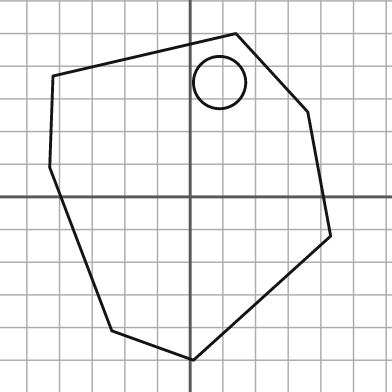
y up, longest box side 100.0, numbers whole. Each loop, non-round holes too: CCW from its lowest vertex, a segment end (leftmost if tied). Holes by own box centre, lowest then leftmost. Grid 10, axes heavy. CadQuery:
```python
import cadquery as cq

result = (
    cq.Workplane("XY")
    .moveTo(1.0, -50.0)
    .lineTo(43.0, -12.0)
    .lineTo(36.0, 26.0)
    .lineTo(14.0, 50.0)
    .lineTo(-42.0, 37.0)
    .lineTo(-43.0, 9.0)
    .lineTo(-24.0, -41.0)
    .close()
    .moveTo(9.0, 35.0)
    .circle(8.0)
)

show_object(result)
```